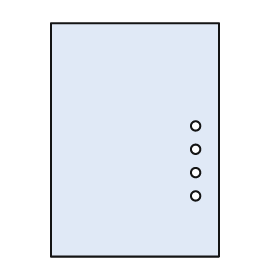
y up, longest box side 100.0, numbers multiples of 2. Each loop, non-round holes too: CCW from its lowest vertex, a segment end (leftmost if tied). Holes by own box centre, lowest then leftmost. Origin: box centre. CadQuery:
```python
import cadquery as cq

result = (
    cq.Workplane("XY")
    .moveTo(-36.0, -50.0)
    .lineTo(36.0, -50.0)
    .lineTo(36.0, 50.0)
    .lineTo(-36.0, 50.0)
    .close()
    .moveTo(26.0, -24.0)
    .circle(2.0)
    .moveTo(26.0, -14.0)
    .circle(2.0)
    .moveTo(26.0, -4.0)
    .circle(2.0)
    .moveTo(26.0, 6.0)
    .circle(2.0)
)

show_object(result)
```